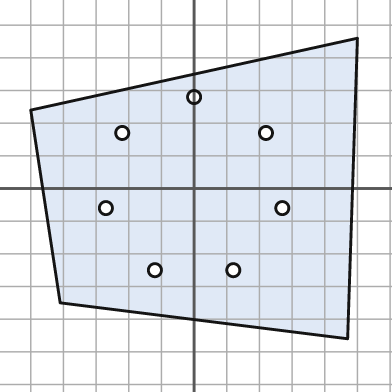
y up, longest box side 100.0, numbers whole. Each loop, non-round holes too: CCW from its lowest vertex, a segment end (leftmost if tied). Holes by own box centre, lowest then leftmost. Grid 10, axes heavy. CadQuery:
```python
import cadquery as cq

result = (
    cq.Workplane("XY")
    .moveTo(47.0, -46.0)
    .lineTo(50.0, 46.0)
    .lineTo(-50.0, 24.0)
    .lineTo(-41.0, -35.0)
    .close()
    .moveTo(-12.0, -25.0)
    .circle(2.0)
    .moveTo(12.0, -25.0)
    .circle(2.0)
    .moveTo(-27.0, -6.0)
    .circle(2.0)
    .moveTo(27.0, -6.0)
    .circle(2.0)
    .moveTo(-22.0, 17.0)
    .circle(2.0)
    .moveTo(22.0, 17.0)
    .circle(2.0)
    .moveTo(0.0, 28.0)
    .circle(2.0)
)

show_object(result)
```